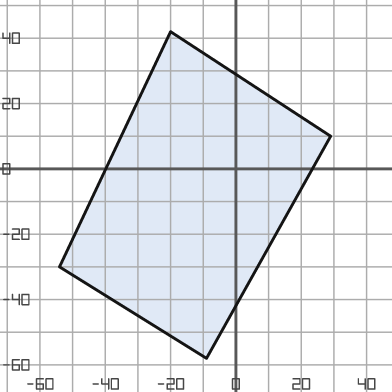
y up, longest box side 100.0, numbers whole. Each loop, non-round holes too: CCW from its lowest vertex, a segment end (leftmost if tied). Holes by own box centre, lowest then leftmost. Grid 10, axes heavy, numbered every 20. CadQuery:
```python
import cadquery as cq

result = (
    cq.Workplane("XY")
    .moveTo(-9.0, -58.0)
    .lineTo(29.0, 10.0)
    .lineTo(-20.0, 42.0)
    .lineTo(-54.0, -30.0)
    .close()
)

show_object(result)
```